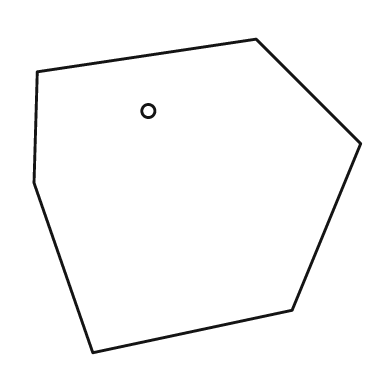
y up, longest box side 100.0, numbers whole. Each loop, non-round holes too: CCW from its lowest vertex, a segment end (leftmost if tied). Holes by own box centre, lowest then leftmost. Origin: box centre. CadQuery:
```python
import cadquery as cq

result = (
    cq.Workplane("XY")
    .moveTo(-32.0, -48.0)
    .lineTo(29.0, -35.0)
    .lineTo(50.0, 16.0)
    .lineTo(18.0, 48.0)
    .lineTo(-49.0, 38.0)
    .lineTo(-50.0, 4.0)
    .close()
    .moveTo(-15.0, 26.0)
    .circle(2.0)
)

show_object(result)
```